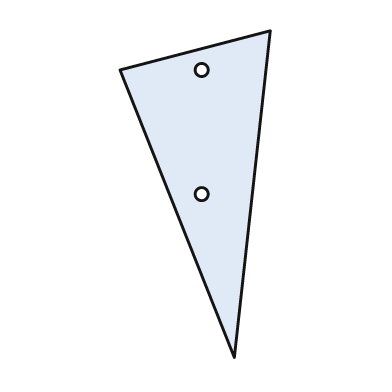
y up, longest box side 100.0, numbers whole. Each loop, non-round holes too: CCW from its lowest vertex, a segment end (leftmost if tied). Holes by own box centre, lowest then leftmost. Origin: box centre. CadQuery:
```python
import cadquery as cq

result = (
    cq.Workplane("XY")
    .moveTo(12.0, -50.0)
    .lineTo(23.0, 50.0)
    .lineTo(-23.0, 38.0)
    .close()
    .moveTo(2.0, 0.0)
    .circle(2.0)
    .moveTo(2.0, 38.0)
    .circle(2.0)
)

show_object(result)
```